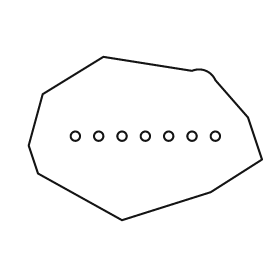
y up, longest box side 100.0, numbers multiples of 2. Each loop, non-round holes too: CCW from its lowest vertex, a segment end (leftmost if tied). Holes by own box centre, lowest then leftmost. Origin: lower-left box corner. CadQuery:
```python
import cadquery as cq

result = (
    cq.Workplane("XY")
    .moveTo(40.0, 0.0)
    .lineTo(78.0, 12.0)
    .lineTo(100.0, 26.0)
    .lineTo(94.0, 44.0)
    .lineTo(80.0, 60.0)
    .threePointArc((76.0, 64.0), (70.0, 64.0))
    .lineTo(32.0, 70.0)
    .lineTo(6.0, 54.0)
    .lineTo(0.0, 32.0)
    .lineTo(4.0, 20.0)
    .close()
    .moveTo(20.0, 36.0)
    .circle(2.0)
    .moveTo(30.0, 36.0)
    .circle(2.0)
    .moveTo(40.0, 36.0)
    .circle(2.0)
    .moveTo(50.0, 36.0)
    .circle(2.0)
    .moveTo(60.0, 36.0)
    .circle(2.0)
    .moveTo(70.0, 36.0)
    .circle(2.0)
    .moveTo(80.0, 36.0)
    .circle(2.0)
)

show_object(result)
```